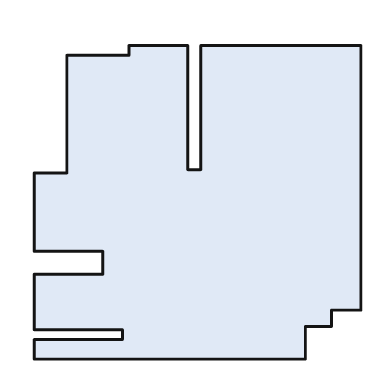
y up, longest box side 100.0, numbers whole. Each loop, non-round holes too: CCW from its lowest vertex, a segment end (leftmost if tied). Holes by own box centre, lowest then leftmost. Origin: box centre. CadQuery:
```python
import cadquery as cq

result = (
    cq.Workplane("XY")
    .moveTo(-50.0, -48.0)
    .lineTo(33.0, -48.0)
    .lineTo(33.0, -38.0)
    .lineTo(41.0, -38.0)
    .lineTo(41.0, -33.0)
    .lineTo(50.0, -33.0)
    .lineTo(50.0, 48.0)
    .lineTo(1.0, 48.0)
    .lineTo(1.0, 10.0)
    .lineTo(-3.0, 10.0)
    .lineTo(-3.0, 48.0)
    .lineTo(-21.0, 48.0)
    .lineTo(-21.0, 45.0)
    .lineTo(-40.0, 45.0)
    .lineTo(-40.0, 9.0)
    .lineTo(-50.0, 9.0)
    .lineTo(-50.0, -15.0)
    .lineTo(-29.0, -15.0)
    .lineTo(-29.0, -22.0)
    .lineTo(-50.0, -22.0)
    .lineTo(-50.0, -39.0)
    .lineTo(-23.0, -39.0)
    .lineTo(-23.0, -42.0)
    .lineTo(-50.0, -42.0)
    .close()
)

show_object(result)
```